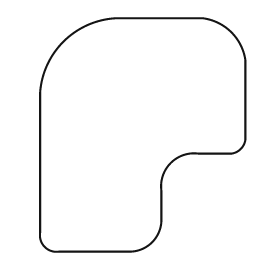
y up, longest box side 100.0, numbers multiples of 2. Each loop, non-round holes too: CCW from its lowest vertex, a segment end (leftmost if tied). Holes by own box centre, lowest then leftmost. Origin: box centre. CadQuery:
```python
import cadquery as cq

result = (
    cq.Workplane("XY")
    .moveTo(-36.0, -50.0)
    .lineTo(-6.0, -50.0)
    .threePointArc((4.0, -46.0), (8.0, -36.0))
    .lineTo(8.0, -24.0)
    .threePointArc((12.0, -12.0), (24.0, -8.0))
    .lineTo(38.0, -8.0)
    .threePointArc((42.0, -6.0), (44.0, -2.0))
    .lineTo(44.0, 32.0)
    .threePointArc((38.0, 44.0), (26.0, 50.0))
    .lineTo(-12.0, 50.0)
    .threePointArc((-34.0, 40.0), (-44.0, 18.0))
    .lineTo(-44.0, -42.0)
    .threePointArc((-42.0, -48.0), (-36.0, -50.0))
    .close()
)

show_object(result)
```